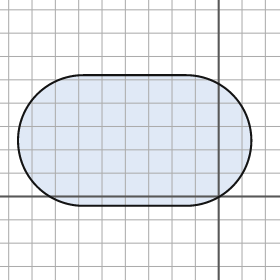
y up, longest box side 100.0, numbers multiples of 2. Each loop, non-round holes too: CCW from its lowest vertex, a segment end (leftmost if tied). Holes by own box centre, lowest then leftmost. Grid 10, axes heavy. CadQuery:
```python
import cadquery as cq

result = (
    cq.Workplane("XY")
    .moveTo(-58.0, -4.0)
    .lineTo(-14.0, -4.0)
    .threePointArc((14.0, 24.0), (-14.0, 52.0))
    .lineTo(-58.0, 52.0)
    .threePointArc((-86.0, 24.0), (-58.0, -4.0))
    .close()
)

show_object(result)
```